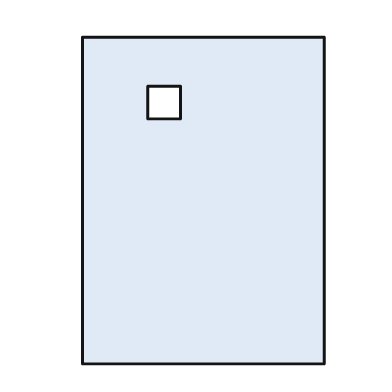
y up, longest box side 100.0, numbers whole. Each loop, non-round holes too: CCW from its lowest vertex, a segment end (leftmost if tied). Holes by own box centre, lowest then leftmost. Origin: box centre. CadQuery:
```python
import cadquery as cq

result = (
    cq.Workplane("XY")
    .moveTo(-37.0, -50.0)
    .lineTo(37.0, -50.0)
    .lineTo(37.0, 50.0)
    .lineTo(-37.0, 50.0)
    .close()
    .moveTo(-17.0, 25.0)
    .lineTo(-7.0, 25.0)
    .lineTo(-7.0, 35.0)
    .lineTo(-17.0, 35.0)
    .close()
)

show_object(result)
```